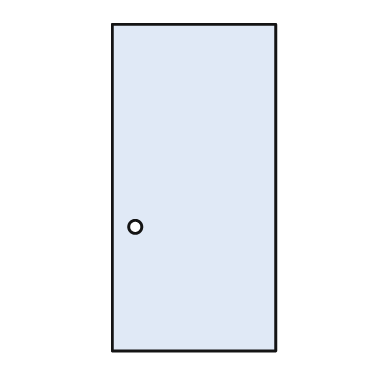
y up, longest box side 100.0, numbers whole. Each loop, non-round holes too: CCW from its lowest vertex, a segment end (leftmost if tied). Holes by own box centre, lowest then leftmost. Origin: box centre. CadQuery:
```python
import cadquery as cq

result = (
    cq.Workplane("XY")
    .moveTo(-25.0, -50.0)
    .lineTo(25.0, -50.0)
    .lineTo(25.0, 50.0)
    .lineTo(-25.0, 50.0)
    .close()
    .moveTo(-18.0, -12.0)
    .circle(2.0)
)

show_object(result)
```